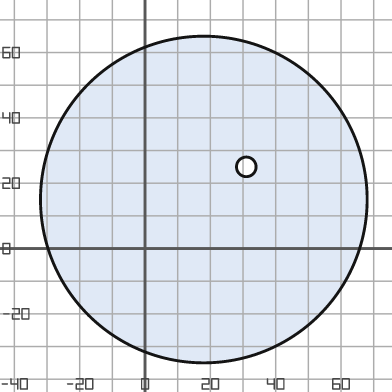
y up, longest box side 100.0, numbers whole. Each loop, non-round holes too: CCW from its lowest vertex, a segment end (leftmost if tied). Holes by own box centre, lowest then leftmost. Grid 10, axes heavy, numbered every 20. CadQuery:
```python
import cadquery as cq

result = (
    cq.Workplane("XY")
    .moveTo(18.0, 15.0)
    .circle(50.0)
    .moveTo(31.0, 25.0)
    .circle(3.0)
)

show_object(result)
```